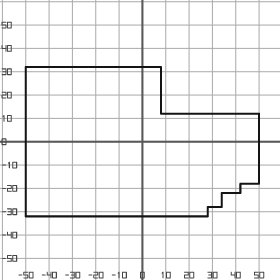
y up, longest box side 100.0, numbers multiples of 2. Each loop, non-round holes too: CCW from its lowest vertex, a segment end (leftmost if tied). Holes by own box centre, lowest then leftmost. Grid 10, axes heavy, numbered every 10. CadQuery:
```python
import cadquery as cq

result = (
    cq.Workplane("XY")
    .moveTo(-50.0, -32.0)
    .lineTo(28.0, -32.0)
    .lineTo(28.0, -28.0)
    .lineTo(34.0, -28.0)
    .lineTo(34.0, -22.0)
    .lineTo(42.0, -22.0)
    .lineTo(42.0, -18.0)
    .lineTo(50.0, -18.0)
    .lineTo(50.0, 12.0)
    .lineTo(8.0, 12.0)
    .lineTo(8.0, 32.0)
    .lineTo(-50.0, 32.0)
    .close()
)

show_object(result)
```